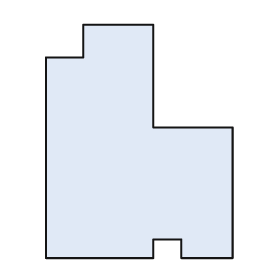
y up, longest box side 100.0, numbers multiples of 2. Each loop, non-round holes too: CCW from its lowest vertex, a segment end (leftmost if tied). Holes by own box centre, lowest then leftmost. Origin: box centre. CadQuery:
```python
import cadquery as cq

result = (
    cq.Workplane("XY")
    .moveTo(-40.0, -50.0)
    .lineTo(6.0, -50.0)
    .lineTo(6.0, -42.0)
    .lineTo(18.0, -42.0)
    .lineTo(18.0, -50.0)
    .lineTo(40.0, -50.0)
    .lineTo(40.0, 6.0)
    .lineTo(6.0, 6.0)
    .lineTo(6.0, 50.0)
    .lineTo(-24.0, 50.0)
    .lineTo(-24.0, 36.0)
    .lineTo(-40.0, 36.0)
    .close()
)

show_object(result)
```